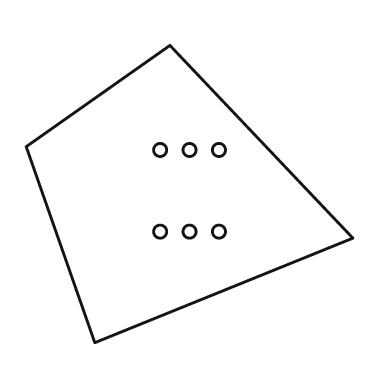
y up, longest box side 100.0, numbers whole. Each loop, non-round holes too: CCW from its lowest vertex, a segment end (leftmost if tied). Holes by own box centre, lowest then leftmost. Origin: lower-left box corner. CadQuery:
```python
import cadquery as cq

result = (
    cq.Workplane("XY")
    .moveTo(21.0, 0.0)
    .lineTo(100.0, 32.0)
    .lineTo(44.0, 91.0)
    .lineTo(0.0, 60.0)
    .close()
    .moveTo(41.0, 34.0)
    .circle(2.0)
    .moveTo(50.0, 34.0)
    .circle(2.0)
    .moveTo(59.0, 34.0)
    .circle(2.0)
    .moveTo(41.0, 59.0)
    .circle(2.0)
    .moveTo(50.0, 59.0)
    .circle(2.0)
    .moveTo(59.0, 59.0)
    .circle(2.0)
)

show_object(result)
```